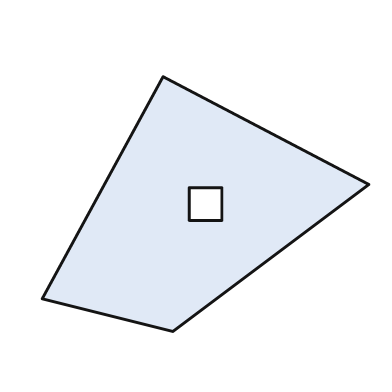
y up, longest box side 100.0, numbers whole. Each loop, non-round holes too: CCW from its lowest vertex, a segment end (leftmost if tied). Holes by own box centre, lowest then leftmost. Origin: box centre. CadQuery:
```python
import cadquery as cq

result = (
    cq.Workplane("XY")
    .moveTo(-10.0, -39.0)
    .lineTo(50.0, 6.0)
    .lineTo(-13.0, 39.0)
    .lineTo(-50.0, -29.0)
    .close()
    .moveTo(-5.0, -5.0)
    .lineTo(5.0, -5.0)
    .lineTo(5.0, 5.0)
    .lineTo(-5.0, 5.0)
    .close()
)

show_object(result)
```